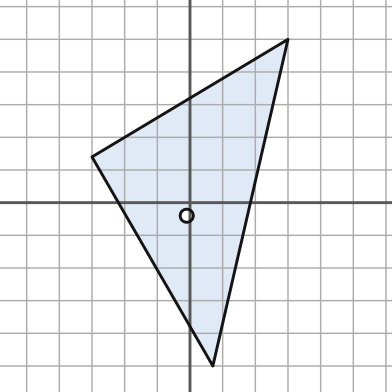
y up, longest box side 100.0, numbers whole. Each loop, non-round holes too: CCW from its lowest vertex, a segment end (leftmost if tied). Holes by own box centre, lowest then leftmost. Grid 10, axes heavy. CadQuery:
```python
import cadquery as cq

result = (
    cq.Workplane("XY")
    .moveTo(7.0, -50.0)
    .lineTo(30.0, 50.0)
    .lineTo(-30.0, 14.0)
    .close()
    .moveTo(-1.0, -4.0)
    .circle(2.0)
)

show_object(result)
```